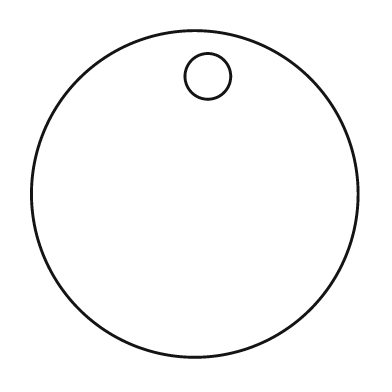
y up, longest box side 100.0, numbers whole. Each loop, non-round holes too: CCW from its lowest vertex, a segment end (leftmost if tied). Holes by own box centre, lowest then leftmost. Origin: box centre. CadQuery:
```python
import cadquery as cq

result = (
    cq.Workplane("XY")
    .moveTo(0.0, 0.0)
    .circle(50.0)
    .moveTo(4.0, 36.0)
    .circle(7.0)
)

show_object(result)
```